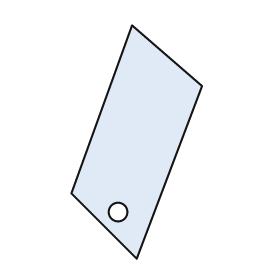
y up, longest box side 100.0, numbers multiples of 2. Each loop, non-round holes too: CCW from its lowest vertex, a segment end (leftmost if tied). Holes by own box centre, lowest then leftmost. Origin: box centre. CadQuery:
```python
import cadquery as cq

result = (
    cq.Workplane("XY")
    .moveTo(0.0, -50.0)
    .lineTo(28.0, 24.0)
    .lineTo(-2.0, 50.0)
    .lineTo(-28.0, -22.0)
    .close()
    .moveTo(-8.0, -30.0)
    .circle(4.0)
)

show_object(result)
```